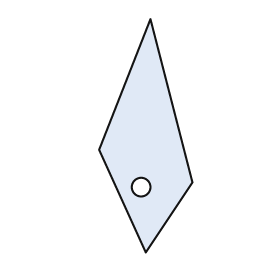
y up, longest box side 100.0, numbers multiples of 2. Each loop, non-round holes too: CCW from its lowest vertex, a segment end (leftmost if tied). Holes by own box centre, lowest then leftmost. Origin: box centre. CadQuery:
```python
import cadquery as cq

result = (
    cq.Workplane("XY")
    .moveTo(0.0, -50.0)
    .lineTo(20.0, -20.0)
    .lineTo(2.0, 50.0)
    .lineTo(-20.0, -6.0)
    .close()
    .moveTo(-2.0, -22.0)
    .circle(4.0)
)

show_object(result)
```